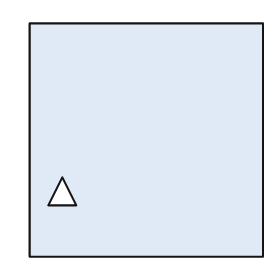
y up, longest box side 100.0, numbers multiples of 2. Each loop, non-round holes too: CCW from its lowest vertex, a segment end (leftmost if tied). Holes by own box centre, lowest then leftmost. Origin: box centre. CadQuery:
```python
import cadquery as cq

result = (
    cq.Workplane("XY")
    .moveTo(-50.0, -50.0)
    .lineTo(50.0, -50.0)
    .lineTo(50.0, 50.0)
    .lineTo(-50.0, 50.0)
    .close()
    .moveTo(-42.0, -28.0)
    .lineTo(-30.0, -28.0)
    .lineTo(-36.0, -16.0)
    .close()
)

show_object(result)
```